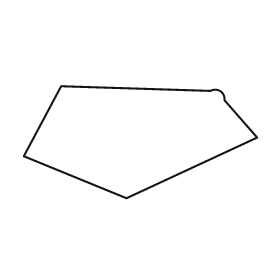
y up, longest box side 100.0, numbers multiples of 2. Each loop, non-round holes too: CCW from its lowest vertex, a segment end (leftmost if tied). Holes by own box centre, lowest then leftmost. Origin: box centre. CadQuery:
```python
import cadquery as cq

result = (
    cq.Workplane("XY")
    .moveTo(-6.0, -24.0)
    .lineTo(50.0, 2.0)
    .lineTo(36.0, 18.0)
    .threePointArc((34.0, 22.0), (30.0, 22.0))
    .lineTo(-34.0, 24.0)
    .lineTo(-50.0, -6.0)
    .close()
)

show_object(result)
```